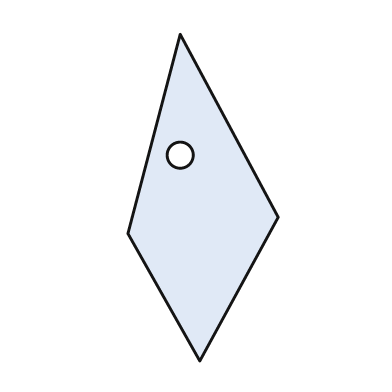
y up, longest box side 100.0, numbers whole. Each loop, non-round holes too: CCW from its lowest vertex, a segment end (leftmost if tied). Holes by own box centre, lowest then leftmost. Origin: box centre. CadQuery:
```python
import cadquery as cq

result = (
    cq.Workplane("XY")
    .moveTo(-1.0, -50.0)
    .lineTo(23.0, -6.0)
    .lineTo(-7.0, 50.0)
    .lineTo(-23.0, -11.0)
    .close()
    .moveTo(-7.0, 13.0)
    .circle(4.0)
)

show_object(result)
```